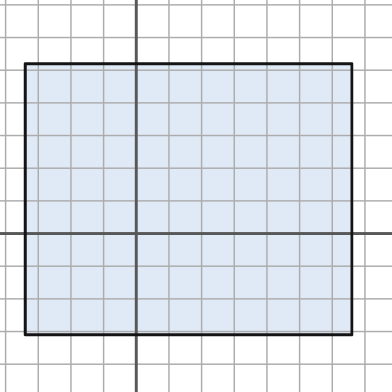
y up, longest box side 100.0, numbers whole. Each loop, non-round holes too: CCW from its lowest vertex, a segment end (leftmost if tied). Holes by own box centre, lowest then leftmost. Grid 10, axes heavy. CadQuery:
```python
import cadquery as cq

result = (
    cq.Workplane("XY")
    .moveTo(-34.0, -31.0)
    .lineTo(66.0, -31.0)
    .lineTo(66.0, 52.0)
    .lineTo(-34.0, 52.0)
    .close()
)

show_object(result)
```